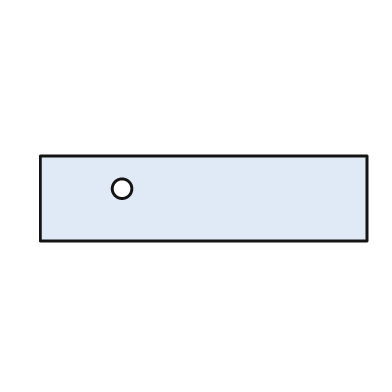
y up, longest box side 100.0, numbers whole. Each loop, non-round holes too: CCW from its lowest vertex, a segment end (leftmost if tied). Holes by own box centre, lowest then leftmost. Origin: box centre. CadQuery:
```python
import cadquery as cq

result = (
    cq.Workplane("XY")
    .moveTo(-50.0, -13.0)
    .lineTo(50.0, -13.0)
    .lineTo(50.0, 13.0)
    .lineTo(-50.0, 13.0)
    .close()
    .moveTo(-25.0, 3.0)
    .circle(3.0)
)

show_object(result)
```